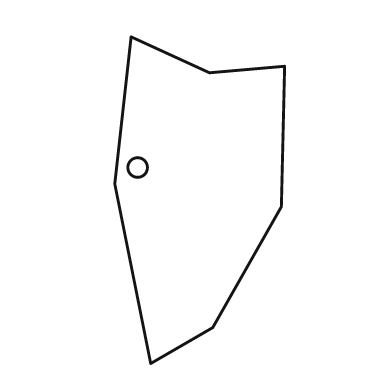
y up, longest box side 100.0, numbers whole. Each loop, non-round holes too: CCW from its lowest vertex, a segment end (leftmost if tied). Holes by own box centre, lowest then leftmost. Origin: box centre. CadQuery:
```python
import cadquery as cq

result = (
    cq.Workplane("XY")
    .moveTo(-15.0, -50.0)
    .lineTo(4.0, -39.0)
    .lineTo(25.0, -2.0)
    .lineTo(26.0, 41.0)
    .lineTo(3.0, 39.0)
    .lineTo(-21.0, 50.0)
    .lineTo(-26.0, 5.0)
    .close()
    .moveTo(-19.0, 10.0)
    .circle(3.0)
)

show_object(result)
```